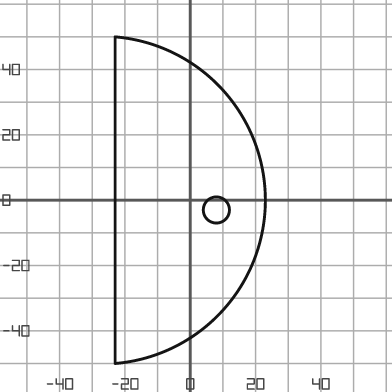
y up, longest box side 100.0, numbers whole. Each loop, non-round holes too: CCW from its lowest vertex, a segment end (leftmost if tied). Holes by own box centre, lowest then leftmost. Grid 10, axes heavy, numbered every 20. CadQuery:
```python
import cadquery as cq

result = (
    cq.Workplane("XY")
    .moveTo(-23.0, -50.0)
    .threePointArc((23.0, 0.0), (-23.0, 50.0))
    .close()
    .moveTo(8.0, -3.0)
    .circle(4.0)
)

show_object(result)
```